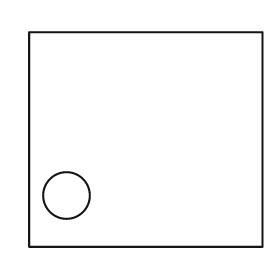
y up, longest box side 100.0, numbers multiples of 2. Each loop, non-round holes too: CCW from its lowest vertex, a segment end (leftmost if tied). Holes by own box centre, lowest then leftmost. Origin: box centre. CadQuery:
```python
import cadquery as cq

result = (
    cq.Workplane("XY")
    .moveTo(-50.0, -46.0)
    .lineTo(50.0, -46.0)
    .lineTo(50.0, 46.0)
    .lineTo(-50.0, 46.0)
    .close()
    .moveTo(-34.0, -24.0)
    .circle(10.0)
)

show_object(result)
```